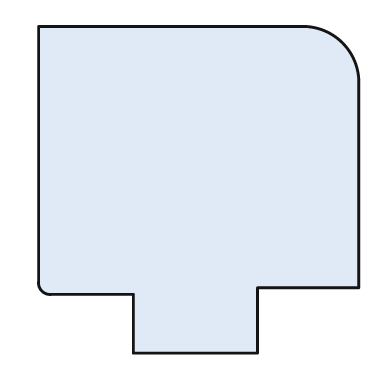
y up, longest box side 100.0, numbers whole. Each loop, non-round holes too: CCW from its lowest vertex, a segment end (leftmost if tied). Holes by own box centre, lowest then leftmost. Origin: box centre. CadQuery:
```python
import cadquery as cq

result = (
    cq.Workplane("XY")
    .moveTo(-20.0, -50.0)
    .lineTo(18.0, -50.0)
    .lineTo(18.0, -30.0)
    .lineTo(49.0, -30.0)
    .lineTo(49.0, 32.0)
    .threePointArc((44.0, 45.0), (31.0, 50.0))
    .lineTo(-49.0, 50.0)
    .lineTo(-49.0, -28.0)
    .threePointArc((-48.0, -31.0), (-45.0, -32.0))
    .lineTo(-20.0, -32.0)
    .close()
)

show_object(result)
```